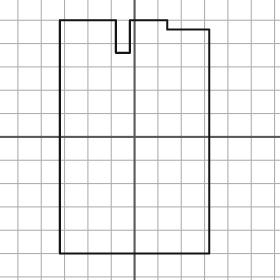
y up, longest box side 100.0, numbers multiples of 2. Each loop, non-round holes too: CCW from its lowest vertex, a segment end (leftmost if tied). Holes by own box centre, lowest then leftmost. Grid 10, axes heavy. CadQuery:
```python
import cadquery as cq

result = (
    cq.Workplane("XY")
    .moveTo(-32.0, -50.0)
    .lineTo(32.0, -50.0)
    .lineTo(32.0, 46.0)
    .lineTo(14.0, 46.0)
    .lineTo(14.0, 50.0)
    .lineTo(-2.0, 50.0)
    .lineTo(-2.0, 36.0)
    .lineTo(-8.0, 36.0)
    .lineTo(-8.0, 50.0)
    .lineTo(-32.0, 50.0)
    .close()
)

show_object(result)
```